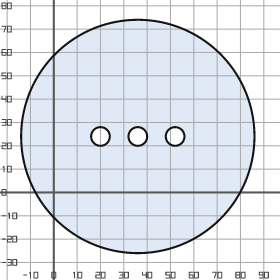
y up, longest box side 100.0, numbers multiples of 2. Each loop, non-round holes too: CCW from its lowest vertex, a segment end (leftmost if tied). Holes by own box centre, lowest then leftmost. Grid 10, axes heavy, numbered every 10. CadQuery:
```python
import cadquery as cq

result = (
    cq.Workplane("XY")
    .moveTo(36.0, 24.0)
    .circle(50.0)
    .moveTo(20.0, 24.0)
    .circle(4.0)
    .moveTo(36.0, 24.0)
    .circle(4.0)
    .moveTo(52.0, 24.0)
    .circle(4.0)
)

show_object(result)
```